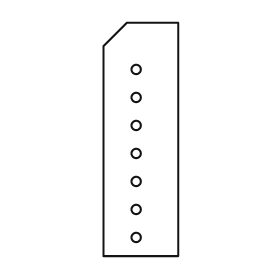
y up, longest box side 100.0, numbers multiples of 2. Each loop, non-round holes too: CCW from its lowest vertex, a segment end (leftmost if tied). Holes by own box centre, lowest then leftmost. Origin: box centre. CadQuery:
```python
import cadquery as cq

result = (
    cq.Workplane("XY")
    .moveTo(-16.0, -50.0)
    .lineTo(16.0, -50.0)
    .lineTo(16.0, 50.0)
    .lineTo(-6.0, 50.0)
    .lineTo(-16.0, 40.0)
    .close()
    .moveTo(-2.0, -42.0)
    .circle(2.0)
    .moveTo(-2.0, -30.0)
    .circle(2.0)
    .moveTo(-2.0, -18.0)
    .circle(2.0)
    .moveTo(-2.0, -6.0)
    .circle(2.0)
    .moveTo(-2.0, 6.0)
    .circle(2.0)
    .moveTo(-2.0, 18.0)
    .circle(2.0)
    .moveTo(-2.0, 30.0)
    .circle(2.0)
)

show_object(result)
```